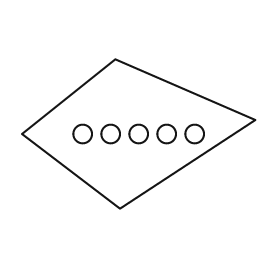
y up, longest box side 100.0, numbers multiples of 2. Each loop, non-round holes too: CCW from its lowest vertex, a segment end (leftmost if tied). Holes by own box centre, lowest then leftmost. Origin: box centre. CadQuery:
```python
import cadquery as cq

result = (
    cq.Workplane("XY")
    .moveTo(-8.0, -32.0)
    .lineTo(50.0, 6.0)
    .lineTo(-10.0, 32.0)
    .lineTo(-50.0, 0.0)
    .close()
    .moveTo(-24.0, 0.0)
    .circle(4.0)
    .moveTo(-12.0, 0.0)
    .circle(4.0)
    .moveTo(0.0, 0.0)
    .circle(4.0)
    .moveTo(12.0, 0.0)
    .circle(4.0)
    .moveTo(24.0, 0.0)
    .circle(4.0)
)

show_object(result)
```